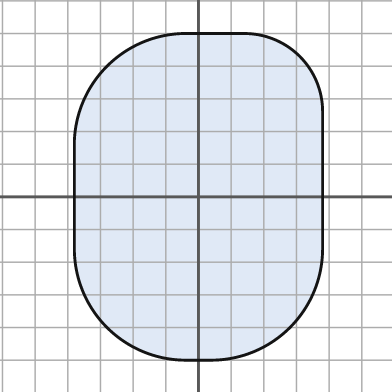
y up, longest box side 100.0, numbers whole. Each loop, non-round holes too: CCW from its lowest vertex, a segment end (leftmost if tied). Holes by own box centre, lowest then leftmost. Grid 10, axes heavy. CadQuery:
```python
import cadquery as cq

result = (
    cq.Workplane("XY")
    .moveTo(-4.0, -50.0)
    .lineTo(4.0, -50.0)
    .threePointArc((28.0, -40.0), (38.0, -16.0))
    .lineTo(38.0, 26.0)
    .threePointArc((31.0, 43.0), (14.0, 50.0))
    .lineTo(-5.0, 50.0)
    .threePointArc((-28.0, 40.0), (-38.0, 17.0))
    .lineTo(-38.0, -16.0)
    .threePointArc((-28.0, -40.0), (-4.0, -50.0))
    .close()
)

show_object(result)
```